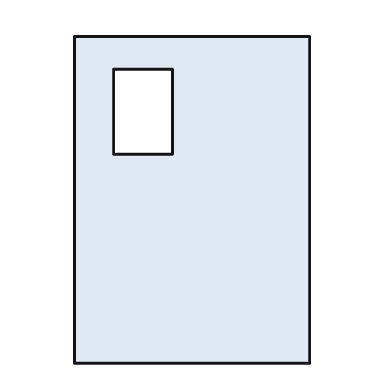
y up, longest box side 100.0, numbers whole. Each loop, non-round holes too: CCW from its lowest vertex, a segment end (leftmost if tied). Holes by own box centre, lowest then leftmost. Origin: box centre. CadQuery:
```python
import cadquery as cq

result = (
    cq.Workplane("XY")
    .moveTo(-36.0, -50.0)
    .lineTo(36.0, -50.0)
    .lineTo(36.0, 50.0)
    .lineTo(-36.0, 50.0)
    .close()
    .moveTo(-24.0, 14.0)
    .lineTo(-6.0, 14.0)
    .lineTo(-6.0, 40.0)
    .lineTo(-24.0, 40.0)
    .close()
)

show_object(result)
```